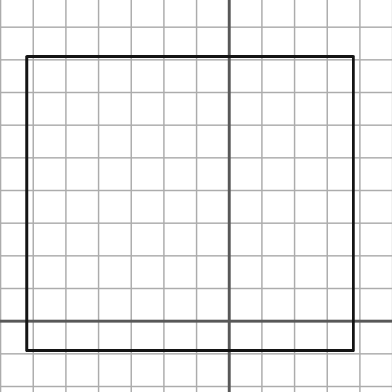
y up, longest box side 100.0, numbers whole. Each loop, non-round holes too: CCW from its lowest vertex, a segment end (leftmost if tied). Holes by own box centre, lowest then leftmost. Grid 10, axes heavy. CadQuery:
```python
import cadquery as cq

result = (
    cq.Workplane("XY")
    .moveTo(-62.0, -9.0)
    .lineTo(38.0, -9.0)
    .lineTo(38.0, 81.0)
    .lineTo(-62.0, 81.0)
    .close()
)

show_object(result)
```